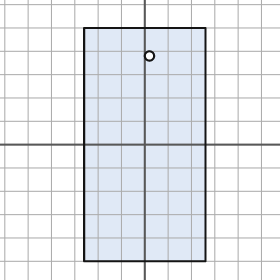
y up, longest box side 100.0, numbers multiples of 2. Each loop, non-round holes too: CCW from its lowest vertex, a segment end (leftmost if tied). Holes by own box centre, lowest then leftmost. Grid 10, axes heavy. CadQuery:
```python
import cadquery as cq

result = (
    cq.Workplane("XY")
    .moveTo(-26.0, -50.0)
    .lineTo(26.0, -50.0)
    .lineTo(26.0, 50.0)
    .lineTo(-26.0, 50.0)
    .close()
    .moveTo(2.0, 38.0)
    .circle(2.0)
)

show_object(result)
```